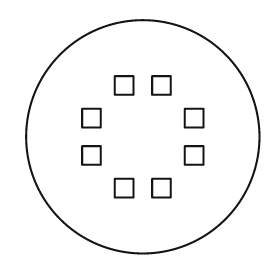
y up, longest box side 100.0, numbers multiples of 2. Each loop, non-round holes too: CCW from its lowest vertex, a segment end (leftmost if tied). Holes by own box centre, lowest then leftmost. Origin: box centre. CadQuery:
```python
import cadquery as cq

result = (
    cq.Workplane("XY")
    .moveTo(0.0, 0.0)
    .circle(50.0)
    .moveTo(-12.0, -26.0)
    .lineTo(-4.0, -26.0)
    .lineTo(-4.0, -18.0)
    .lineTo(-12.0, -18.0)
    .close()
    .moveTo(4.0, -26.0)
    .lineTo(12.0, -26.0)
    .lineTo(12.0, -18.0)
    .lineTo(4.0, -18.0)
    .close()
    .moveTo(-26.0, -12.0)
    .lineTo(-18.0, -12.0)
    .lineTo(-18.0, -4.0)
    .lineTo(-26.0, -4.0)
    .close()
    .moveTo(18.0, -12.0)
    .lineTo(26.0, -12.0)
    .lineTo(26.0, -4.0)
    .lineTo(18.0, -4.0)
    .close()
    .moveTo(-26.0, 4.0)
    .lineTo(-18.0, 4.0)
    .lineTo(-18.0, 12.0)
    .lineTo(-26.0, 12.0)
    .close()
    .moveTo(18.0, 4.0)
    .lineTo(26.0, 4.0)
    .lineTo(26.0, 12.0)
    .lineTo(18.0, 12.0)
    .close()
    .moveTo(-12.0, 18.0)
    .lineTo(-4.0, 18.0)
    .lineTo(-4.0, 26.0)
    .lineTo(-12.0, 26.0)
    .close()
    .moveTo(4.0, 18.0)
    .lineTo(12.0, 18.0)
    .lineTo(12.0, 26.0)
    .lineTo(4.0, 26.0)
    .close()
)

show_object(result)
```